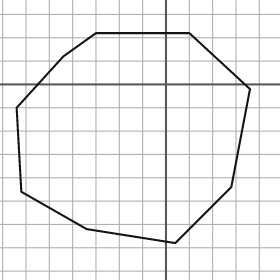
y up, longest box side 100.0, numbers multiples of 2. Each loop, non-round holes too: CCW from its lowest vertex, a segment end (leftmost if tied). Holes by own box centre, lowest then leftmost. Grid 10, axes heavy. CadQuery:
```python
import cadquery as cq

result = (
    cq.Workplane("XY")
    .moveTo(4.0, -68.0)
    .lineTo(28.0, -44.0)
    .lineTo(36.0, -2.0)
    .lineTo(10.0, 22.0)
    .lineTo(-30.0, 22.0)
    .lineTo(-44.0, 12.0)
    .lineTo(-64.0, -10.0)
    .lineTo(-62.0, -46.0)
    .lineTo(-34.0, -62.0)
    .close()
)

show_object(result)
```